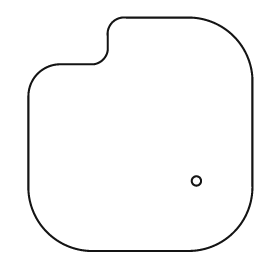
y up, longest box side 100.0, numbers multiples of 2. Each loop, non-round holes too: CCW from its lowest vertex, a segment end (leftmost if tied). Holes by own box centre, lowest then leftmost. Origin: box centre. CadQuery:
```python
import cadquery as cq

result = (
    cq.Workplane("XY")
    .moveTo(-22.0, -50.0)
    .lineTo(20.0, -50.0)
    .threePointArc((40.0, -42.0), (48.0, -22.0))
    .lineTo(48.0, 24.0)
    .threePointArc((40.0, 42.0), (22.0, 50.0))
    .lineTo(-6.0, 50.0)
    .threePointArc((-12.0, 48.0), (-14.0, 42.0))
    .lineTo(-14.0, 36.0)
    .threePointArc((-16.0, 32.0), (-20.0, 30.0))
    .lineTo(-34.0, 30.0)
    .threePointArc((-44.0, 26.0), (-48.0, 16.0))
    .lineTo(-48.0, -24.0)
    .threePointArc((-40.0, -42.0), (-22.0, -50.0))
    .close()
    .moveTo(24.0, -20.0)
    .circle(2.0)
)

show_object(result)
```